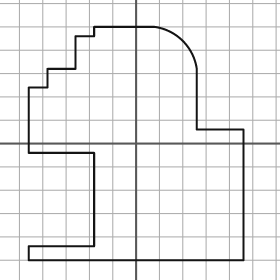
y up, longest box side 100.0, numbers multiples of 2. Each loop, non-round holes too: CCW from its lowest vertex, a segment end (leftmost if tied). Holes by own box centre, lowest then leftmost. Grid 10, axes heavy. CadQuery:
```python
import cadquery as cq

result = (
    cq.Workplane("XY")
    .moveTo(-46.0, -50.0)
    .lineTo(46.0, -50.0)
    .lineTo(46.0, 6.0)
    .lineTo(26.0, 6.0)
    .lineTo(26.0, 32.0)
    .threePointArc((20.0, 44.0), (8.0, 50.0))
    .lineTo(-18.0, 50.0)
    .lineTo(-18.0, 46.0)
    .lineTo(-26.0, 46.0)
    .lineTo(-26.0, 32.0)
    .lineTo(-38.0, 32.0)
    .lineTo(-38.0, 24.0)
    .lineTo(-46.0, 24.0)
    .lineTo(-46.0, -4.0)
    .lineTo(-18.0, -4.0)
    .lineTo(-18.0, -44.0)
    .lineTo(-46.0, -44.0)
    .close()
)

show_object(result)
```